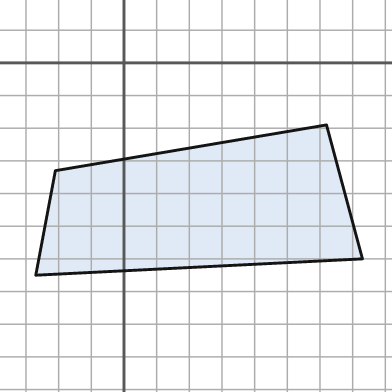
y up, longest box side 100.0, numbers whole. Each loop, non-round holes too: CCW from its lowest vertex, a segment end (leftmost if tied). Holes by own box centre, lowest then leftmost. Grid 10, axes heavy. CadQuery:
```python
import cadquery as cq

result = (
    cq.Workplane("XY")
    .moveTo(-27.0, -65.0)
    .lineTo(73.0, -60.0)
    .lineTo(62.0, -19.0)
    .lineTo(-21.0, -33.0)
    .close()
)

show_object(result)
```